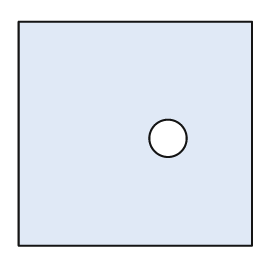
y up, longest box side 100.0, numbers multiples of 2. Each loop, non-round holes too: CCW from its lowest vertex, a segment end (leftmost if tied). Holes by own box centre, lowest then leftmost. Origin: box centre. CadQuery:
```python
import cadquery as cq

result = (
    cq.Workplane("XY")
    .moveTo(-50.0, -48.0)
    .lineTo(50.0, -48.0)
    .lineTo(50.0, 48.0)
    .lineTo(-50.0, 48.0)
    .close()
    .moveTo(14.0, -2.0)
    .circle(8.0)
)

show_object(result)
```